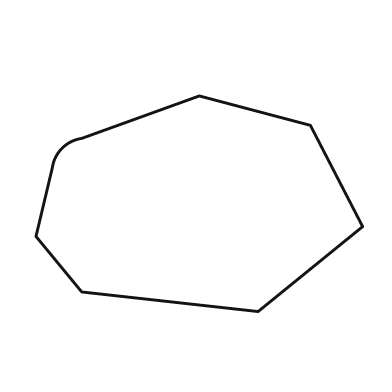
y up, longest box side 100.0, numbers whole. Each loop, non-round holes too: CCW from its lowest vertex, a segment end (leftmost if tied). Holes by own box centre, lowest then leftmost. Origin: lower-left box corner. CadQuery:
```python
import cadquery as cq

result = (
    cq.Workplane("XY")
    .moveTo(68.0, 0.0)
    .lineTo(100.0, 26.0)
    .lineTo(84.0, 57.0)
    .lineTo(50.0, 66.0)
    .lineTo(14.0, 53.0)
    .threePointArc((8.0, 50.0), (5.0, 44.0))
    .lineTo(0.0, 23.0)
    .lineTo(14.0, 6.0)
    .close()
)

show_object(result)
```